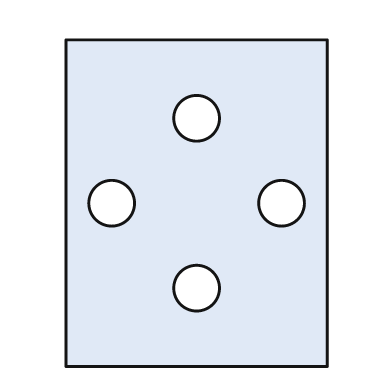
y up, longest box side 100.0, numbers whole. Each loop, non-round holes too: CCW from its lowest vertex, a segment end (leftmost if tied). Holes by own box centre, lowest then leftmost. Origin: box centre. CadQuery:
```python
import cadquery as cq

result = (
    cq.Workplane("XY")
    .moveTo(-40.0, -50.0)
    .lineTo(40.0, -50.0)
    .lineTo(40.0, 50.0)
    .lineTo(-40.0, 50.0)
    .close()
    .moveTo(0.0, -26.0)
    .circle(7.0)
    .moveTo(-26.0, 0.0)
    .circle(7.0)
    .moveTo(26.0, 0.0)
    .circle(7.0)
    .moveTo(0.0, 26.0)
    .circle(7.0)
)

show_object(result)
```